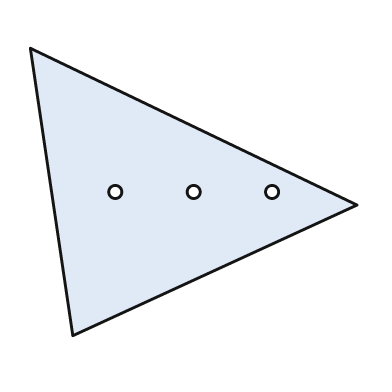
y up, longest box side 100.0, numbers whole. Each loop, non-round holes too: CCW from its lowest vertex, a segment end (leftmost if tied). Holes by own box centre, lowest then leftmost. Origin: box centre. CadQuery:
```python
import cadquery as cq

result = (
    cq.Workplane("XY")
    .moveTo(-37.0, -44.0)
    .lineTo(50.0, -4.0)
    .lineTo(-50.0, 44.0)
    .close()
    .moveTo(-24.0, 0.0)
    .circle(2.0)
    .moveTo(0.0, 0.0)
    .circle(2.0)
    .moveTo(24.0, 0.0)
    .circle(2.0)
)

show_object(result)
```